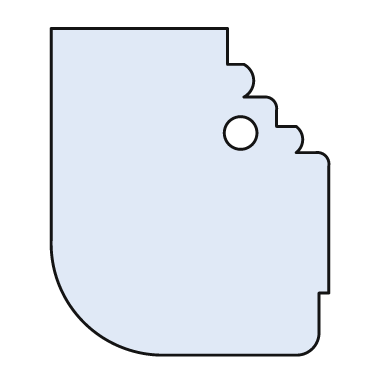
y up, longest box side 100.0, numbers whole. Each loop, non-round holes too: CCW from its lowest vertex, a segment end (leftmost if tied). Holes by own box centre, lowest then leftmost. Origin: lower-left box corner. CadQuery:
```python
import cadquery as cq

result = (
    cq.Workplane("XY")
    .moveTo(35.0, 0.0)
    .lineTo(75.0, 0.0)
    .threePointArc((80.0, 2.0), (82.0, 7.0))
    .lineTo(82.0, 19.0)
    .lineTo(85.0, 19.0)
    .lineTo(85.0, 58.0)
    .threePointArc((84.0, 61.0), (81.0, 62.0))
    .lineTo(75.0, 62.0)
    .threePointArc((77.0, 66.0), (75.0, 70.0))
    .lineTo(69.0, 70.0)
    .lineTo(69.0, 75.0)
    .threePointArc((68.0, 78.0), (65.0, 79.0))
    .lineTo(59.0, 79.0)
    .threePointArc((62.0, 84.0), (59.0, 89.0))
    .lineTo(54.0, 89.0)
    .lineTo(54.0, 100.0)
    .lineTo(0.0, 100.0)
    .lineTo(0.0, 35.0)
    .threePointArc((10.0, 10.0), (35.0, 0.0))
    .close()
    .moveTo(58.0, 68.0)
    .circle(5.0)
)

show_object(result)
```